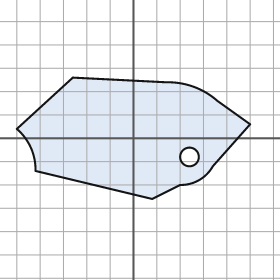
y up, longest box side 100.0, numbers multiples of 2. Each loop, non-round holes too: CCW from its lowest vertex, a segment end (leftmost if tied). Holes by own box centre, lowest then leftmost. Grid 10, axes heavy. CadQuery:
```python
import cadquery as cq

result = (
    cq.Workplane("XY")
    .moveTo(8.0, -26.0)
    .lineTo(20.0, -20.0)
    .threePointArc((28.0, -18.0), (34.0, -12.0))
    .lineTo(50.0, 6.0)
    .lineTo(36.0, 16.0)
    .threePointArc((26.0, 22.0), (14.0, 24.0))
    .lineTo(-26.0, 26.0)
    .lineTo(-50.0, 4.0)
    .threePointArc((-44.0, -4.0), (-42.0, -14.0))
    .close()
    .moveTo(24.0, -8.0)
    .circle(4.0)
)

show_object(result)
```